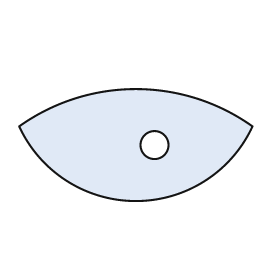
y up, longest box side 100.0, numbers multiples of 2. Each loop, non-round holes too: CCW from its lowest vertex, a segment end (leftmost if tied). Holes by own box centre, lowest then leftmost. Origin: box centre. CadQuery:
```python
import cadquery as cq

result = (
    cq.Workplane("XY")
    .moveTo(-50.0, 8.0)
    .threePointArc((0.0, -24.0), (50.0, 8.0))
    .threePointArc((0.0, 24.0), (-50.0, 8.0))
    .close()
    .moveTo(8.0, 0.0)
    .circle(6.0)
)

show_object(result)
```